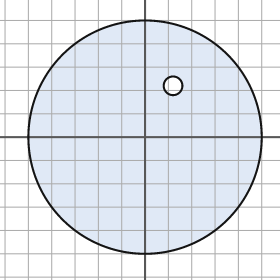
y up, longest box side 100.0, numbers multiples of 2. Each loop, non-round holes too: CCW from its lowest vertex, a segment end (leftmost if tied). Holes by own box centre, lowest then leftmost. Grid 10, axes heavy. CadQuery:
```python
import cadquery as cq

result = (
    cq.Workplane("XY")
    .moveTo(0.0, 0.0)
    .circle(50.0)
    .moveTo(12.0, 22.0)
    .circle(4.0)
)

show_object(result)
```